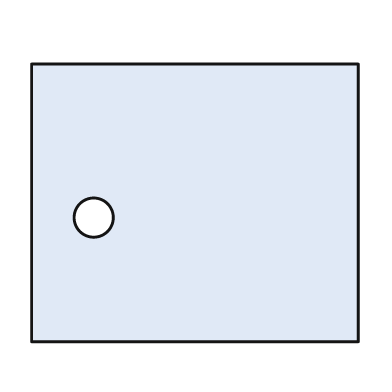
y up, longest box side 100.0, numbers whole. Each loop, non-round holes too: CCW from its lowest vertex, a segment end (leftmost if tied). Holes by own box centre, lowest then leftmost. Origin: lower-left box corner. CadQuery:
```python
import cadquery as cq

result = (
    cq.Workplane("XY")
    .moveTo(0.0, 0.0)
    .lineTo(100.0, 0.0)
    .lineTo(100.0, 85.0)
    .lineTo(0.0, 85.0)
    .close()
    .moveTo(19.0, 38.0)
    .circle(6.0)
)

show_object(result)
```